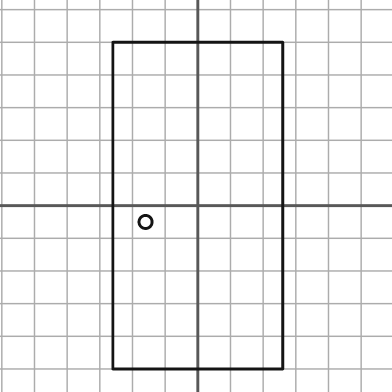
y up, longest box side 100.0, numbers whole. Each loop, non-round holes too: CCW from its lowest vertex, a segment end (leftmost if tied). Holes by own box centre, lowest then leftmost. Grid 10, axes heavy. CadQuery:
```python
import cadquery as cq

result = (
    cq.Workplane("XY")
    .moveTo(-26.0, -50.0)
    .lineTo(26.0, -50.0)
    .lineTo(26.0, 50.0)
    .lineTo(-26.0, 50.0)
    .close()
    .moveTo(-16.0, -5.0)
    .circle(2.0)
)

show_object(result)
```